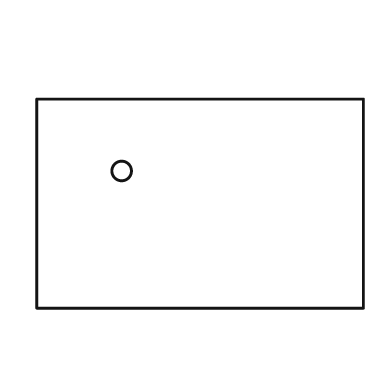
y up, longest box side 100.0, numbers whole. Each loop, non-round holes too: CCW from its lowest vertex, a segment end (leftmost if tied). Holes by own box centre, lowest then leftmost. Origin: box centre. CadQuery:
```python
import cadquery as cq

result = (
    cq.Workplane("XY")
    .moveTo(-50.0, -32.0)
    .lineTo(50.0, -32.0)
    .lineTo(50.0, 32.0)
    .lineTo(-50.0, 32.0)
    .close()
    .moveTo(-24.0, 10.0)
    .circle(3.0)
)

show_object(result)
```